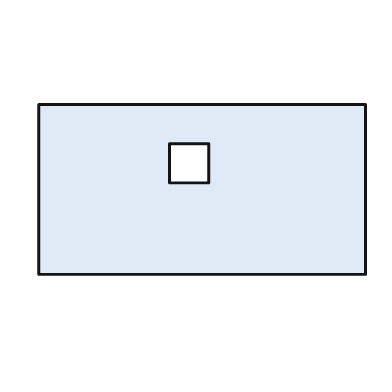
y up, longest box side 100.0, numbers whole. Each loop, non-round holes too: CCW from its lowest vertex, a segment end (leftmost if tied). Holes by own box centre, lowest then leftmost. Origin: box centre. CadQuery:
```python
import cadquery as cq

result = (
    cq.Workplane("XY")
    .moveTo(-50.0, -26.0)
    .lineTo(50.0, -26.0)
    .lineTo(50.0, 26.0)
    .lineTo(-50.0, 26.0)
    .close()
    .moveTo(-10.0, 2.0)
    .lineTo(2.0, 2.0)
    .lineTo(2.0, 14.0)
    .lineTo(-10.0, 14.0)
    .close()
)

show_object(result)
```